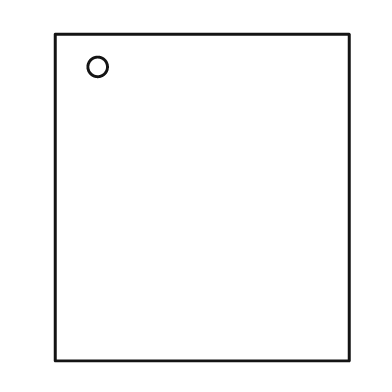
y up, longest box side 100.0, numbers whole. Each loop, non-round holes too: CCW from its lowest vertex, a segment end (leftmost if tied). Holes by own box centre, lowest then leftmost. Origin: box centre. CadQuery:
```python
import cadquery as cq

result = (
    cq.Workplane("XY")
    .moveTo(-45.0, -50.0)
    .lineTo(45.0, -50.0)
    .lineTo(45.0, 50.0)
    .lineTo(-45.0, 50.0)
    .close()
    .moveTo(-32.0, 40.0)
    .circle(3.0)
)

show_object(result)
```